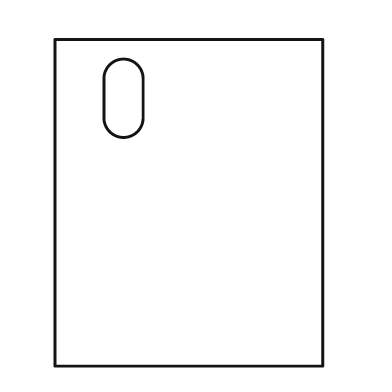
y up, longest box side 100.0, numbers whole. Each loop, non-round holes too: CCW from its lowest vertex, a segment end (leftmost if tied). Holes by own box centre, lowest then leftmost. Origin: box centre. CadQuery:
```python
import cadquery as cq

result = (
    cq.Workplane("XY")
    .moveTo(-41.0, -50.0)
    .lineTo(41.0, -50.0)
    .lineTo(41.0, 50.0)
    .lineTo(-41.0, 50.0)
    .close()
    .moveTo(-26.0, 26.0)
    .threePointArc((-20.0, 20.0), (-14.0, 26.0))
    .lineTo(-14.0, 38.0)
    .threePointArc((-20.0, 44.0), (-26.0, 38.0))
    .close()
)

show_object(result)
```